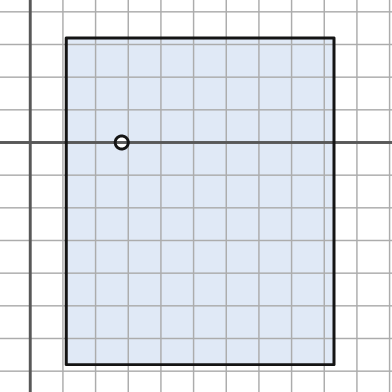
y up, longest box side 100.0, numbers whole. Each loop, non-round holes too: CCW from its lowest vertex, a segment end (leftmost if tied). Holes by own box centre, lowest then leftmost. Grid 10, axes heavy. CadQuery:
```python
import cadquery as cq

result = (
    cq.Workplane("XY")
    .moveTo(11.0, -68.0)
    .lineTo(93.0, -68.0)
    .lineTo(93.0, 32.0)
    .lineTo(11.0, 32.0)
    .close()
    .moveTo(28.0, 0.0)
    .circle(2.0)
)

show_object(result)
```